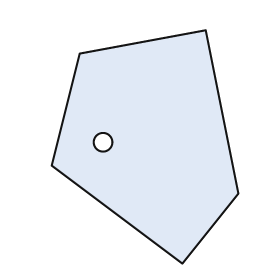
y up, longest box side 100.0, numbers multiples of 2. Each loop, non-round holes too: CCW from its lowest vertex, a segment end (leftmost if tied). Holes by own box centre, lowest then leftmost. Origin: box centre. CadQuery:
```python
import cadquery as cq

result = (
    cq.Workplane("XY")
    .moveTo(16.0, -50.0)
    .lineTo(40.0, -20.0)
    .lineTo(26.0, 50.0)
    .lineTo(-28.0, 40.0)
    .lineTo(-40.0, -8.0)
    .close()
    .moveTo(-18.0, 2.0)
    .circle(4.0)
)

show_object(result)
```